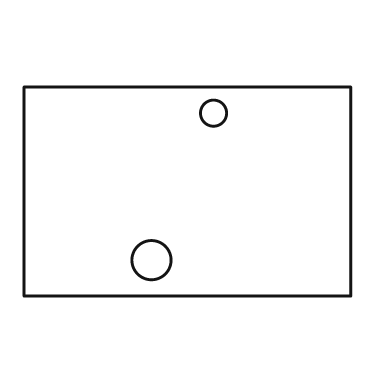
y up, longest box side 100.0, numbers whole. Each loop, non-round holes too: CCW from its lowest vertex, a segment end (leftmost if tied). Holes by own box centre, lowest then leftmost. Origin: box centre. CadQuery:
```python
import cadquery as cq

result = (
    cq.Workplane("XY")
    .moveTo(-50.0, -32.0)
    .lineTo(50.0, -32.0)
    .lineTo(50.0, 32.0)
    .lineTo(-50.0, 32.0)
    .close()
    .moveTo(-11.0, -21.0)
    .circle(6.0)
    .moveTo(8.0, 24.0)
    .circle(4.0)
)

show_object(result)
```